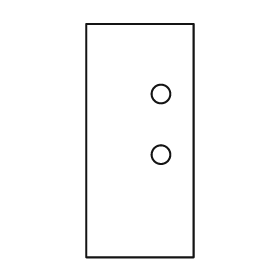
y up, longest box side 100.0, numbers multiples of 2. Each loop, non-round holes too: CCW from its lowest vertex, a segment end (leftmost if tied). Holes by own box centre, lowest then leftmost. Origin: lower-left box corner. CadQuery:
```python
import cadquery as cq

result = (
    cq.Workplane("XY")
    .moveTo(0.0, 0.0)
    .lineTo(46.0, 0.0)
    .lineTo(46.0, 100.0)
    .lineTo(0.0, 100.0)
    .close()
    .moveTo(32.0, 44.0)
    .circle(4.0)
    .moveTo(32.0, 70.0)
    .circle(4.0)
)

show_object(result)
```